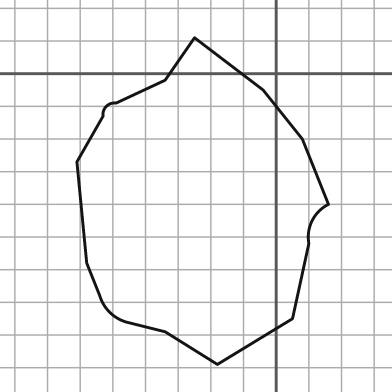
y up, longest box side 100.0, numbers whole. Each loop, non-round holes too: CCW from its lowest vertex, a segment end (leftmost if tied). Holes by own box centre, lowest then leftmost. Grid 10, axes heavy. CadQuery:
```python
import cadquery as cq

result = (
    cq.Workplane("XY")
    .moveTo(-18.0, -89.0)
    .lineTo(5.0, -75.0)
    .lineTo(10.0, -52.0)
    .threePointArc((11.0, -45.0), (16.0, -40.0))
    .lineTo(8.0, -20.0)
    .lineTo(-4.0, -5.0)
    .lineTo(-25.0, 11.0)
    .lineTo(-34.0, -2.0)
    .lineTo(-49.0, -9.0)
    .threePointArc((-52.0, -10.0), (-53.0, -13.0))
    .lineTo(-61.0, -27.0)
    .lineTo(-58.0, -58.0)
    .lineTo(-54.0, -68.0)
    .threePointArc((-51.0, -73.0), (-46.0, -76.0))
    .lineTo(-34.0, -79.0)
    .close()
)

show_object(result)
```